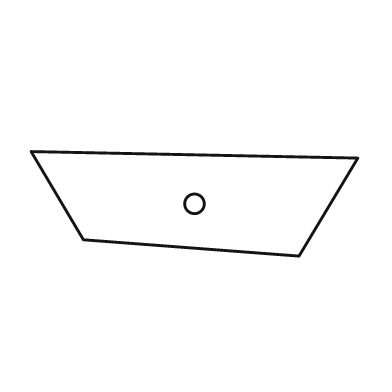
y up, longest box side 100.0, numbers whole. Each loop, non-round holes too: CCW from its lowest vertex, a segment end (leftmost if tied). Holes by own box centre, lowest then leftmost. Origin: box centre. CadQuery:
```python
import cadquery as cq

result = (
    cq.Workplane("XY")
    .moveTo(32.0, -16.0)
    .lineTo(50.0, 14.0)
    .lineTo(-50.0, 16.0)
    .lineTo(-34.0, -11.0)
    .close()
    .moveTo(0.0, 0.0)
    .circle(3.0)
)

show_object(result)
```